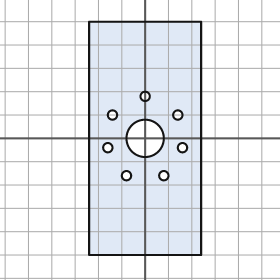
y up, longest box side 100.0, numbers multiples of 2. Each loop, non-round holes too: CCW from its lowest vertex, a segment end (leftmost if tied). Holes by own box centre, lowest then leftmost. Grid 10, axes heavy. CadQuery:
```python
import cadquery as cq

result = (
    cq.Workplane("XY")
    .moveTo(-24.0, -50.0)
    .lineTo(24.0, -50.0)
    .lineTo(24.0, 50.0)
    .lineTo(-24.0, 50.0)
    .close()
    .moveTo(-8.0, -16.0)
    .circle(2.0)
    .moveTo(8.0, -16.0)
    .circle(2.0)
    .moveTo(-16.0, -4.0)
    .circle(2.0)
    .moveTo(16.0, -4.0)
    .circle(2.0)
    .moveTo(0.0, 0.0)
    .circle(8.0)
    .moveTo(-14.0, 10.0)
    .circle(2.0)
    .moveTo(14.0, 10.0)
    .circle(2.0)
    .moveTo(0.0, 18.0)
    .circle(2.0)
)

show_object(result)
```